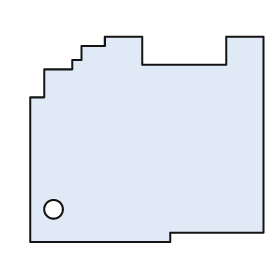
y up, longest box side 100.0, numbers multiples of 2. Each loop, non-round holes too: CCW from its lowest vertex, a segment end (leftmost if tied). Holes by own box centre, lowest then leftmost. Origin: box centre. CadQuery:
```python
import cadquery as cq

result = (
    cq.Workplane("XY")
    .moveTo(-50.0, -44.0)
    .lineTo(10.0, -44.0)
    .lineTo(10.0, -40.0)
    .lineTo(50.0, -40.0)
    .lineTo(50.0, 44.0)
    .lineTo(34.0, 44.0)
    .lineTo(34.0, 32.0)
    .lineTo(-2.0, 32.0)
    .lineTo(-2.0, 44.0)
    .lineTo(-18.0, 44.0)
    .lineTo(-18.0, 40.0)
    .lineTo(-28.0, 40.0)
    .lineTo(-28.0, 34.0)
    .lineTo(-32.0, 34.0)
    .lineTo(-32.0, 30.0)
    .lineTo(-44.0, 30.0)
    .lineTo(-44.0, 18.0)
    .lineTo(-50.0, 18.0)
    .close()
    .moveTo(-40.0, -30.0)
    .circle(4.0)
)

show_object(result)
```